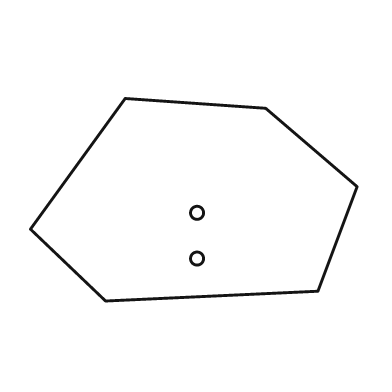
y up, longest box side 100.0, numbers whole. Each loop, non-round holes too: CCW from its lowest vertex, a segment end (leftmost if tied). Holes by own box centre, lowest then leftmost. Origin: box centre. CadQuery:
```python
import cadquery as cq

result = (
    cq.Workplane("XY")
    .moveTo(-27.0, -31.0)
    .lineTo(38.0, -28.0)
    .lineTo(50.0, 4.0)
    .lineTo(22.0, 28.0)
    .lineTo(-21.0, 31.0)
    .lineTo(-50.0, -9.0)
    .close()
    .moveTo(1.0, -18.0)
    .circle(2.0)
    .moveTo(1.0, -4.0)
    .circle(2.0)
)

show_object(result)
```